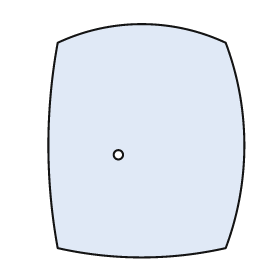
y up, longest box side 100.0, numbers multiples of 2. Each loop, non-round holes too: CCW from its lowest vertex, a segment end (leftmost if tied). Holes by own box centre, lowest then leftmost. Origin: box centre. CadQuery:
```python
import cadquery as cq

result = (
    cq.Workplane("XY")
    .moveTo(-38.0, -46.0)
    .threePointArc((-2.0, -50.0), (34.0, -46.0))
    .threePointArc((42.0, -2.0), (34.0, 42.0))
    .threePointArc((-2.0, 50.0), (-38.0, 42.0))
    .threePointArc((-42.0, -2.0), (-38.0, -46.0))
    .close()
    .moveTo(-12.0, -6.0)
    .circle(2.0)
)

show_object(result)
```